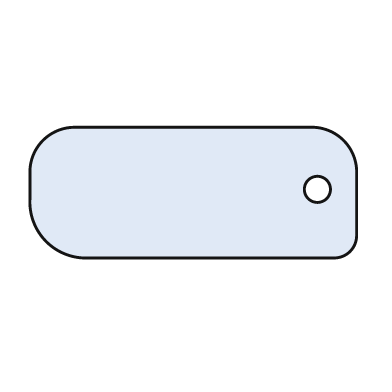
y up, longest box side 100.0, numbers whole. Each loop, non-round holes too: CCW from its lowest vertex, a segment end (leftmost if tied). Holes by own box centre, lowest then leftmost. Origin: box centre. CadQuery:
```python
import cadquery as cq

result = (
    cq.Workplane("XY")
    .moveTo(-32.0, -20.0)
    .lineTo(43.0, -20.0)
    .threePointArc((48.0, -18.0), (50.0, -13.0))
    .lineTo(50.0, 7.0)
    .threePointArc((46.0, 16.0), (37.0, 20.0))
    .lineTo(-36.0, 20.0)
    .threePointArc((-46.0, 16.0), (-50.0, 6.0))
    .lineTo(-50.0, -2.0)
    .threePointArc((-45.0, -15.0), (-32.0, -20.0))
    .close()
    .moveTo(38.0, 1.0)
    .circle(4.0)
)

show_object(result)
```